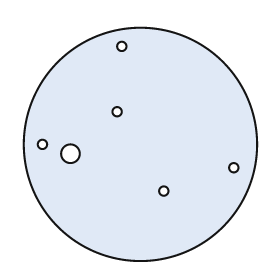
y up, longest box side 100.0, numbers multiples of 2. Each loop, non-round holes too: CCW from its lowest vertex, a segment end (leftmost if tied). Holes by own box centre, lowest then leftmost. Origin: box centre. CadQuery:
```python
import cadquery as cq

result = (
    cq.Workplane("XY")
    .moveTo(0.0, 0.0)
    .circle(50.0)
    .moveTo(10.0, -20.0)
    .circle(2.0)
    .moveTo(40.0, -10.0)
    .circle(2.0)
    .moveTo(-30.0, -4.0)
    .circle(4.0)
    .moveTo(-42.0, 0.0)
    .circle(2.0)
    .moveTo(-10.0, 14.0)
    .circle(2.0)
    .moveTo(-8.0, 42.0)
    .circle(2.0)
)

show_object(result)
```